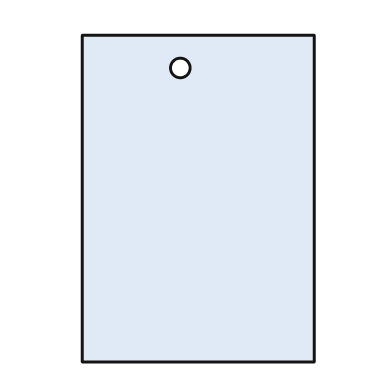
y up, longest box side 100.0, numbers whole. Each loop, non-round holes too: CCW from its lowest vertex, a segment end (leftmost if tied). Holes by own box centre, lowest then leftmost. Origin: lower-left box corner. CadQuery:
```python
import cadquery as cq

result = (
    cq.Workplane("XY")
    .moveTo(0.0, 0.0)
    .lineTo(71.0, 0.0)
    .lineTo(71.0, 100.0)
    .lineTo(0.0, 100.0)
    .close()
    .moveTo(30.0, 90.0)
    .circle(3.0)
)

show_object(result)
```